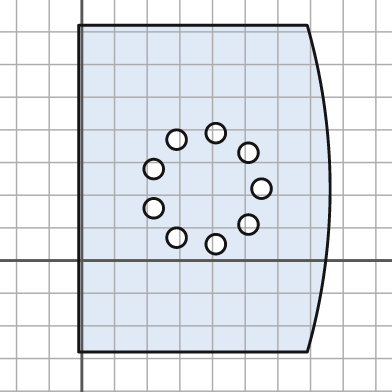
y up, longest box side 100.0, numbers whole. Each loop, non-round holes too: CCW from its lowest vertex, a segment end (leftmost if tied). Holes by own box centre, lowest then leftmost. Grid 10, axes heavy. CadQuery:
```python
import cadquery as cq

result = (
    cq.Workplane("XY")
    .moveTo(-1.0, -28.0)
    .lineTo(69.0, -28.0)
    .threePointArc((76.0, 22.0), (69.0, 72.0))
    .lineTo(-1.0, 72.0)
    .close()
    .moveTo(41.0, 5.0)
    .circle(3.0)
    .moveTo(29.0, 7.0)
    .circle(3.0)
    .moveTo(51.0, 11.0)
    .circle(3.0)
    .moveTo(22.0, 16.0)
    .circle(3.0)
    .moveTo(55.0, 22.0)
    .circle(3.0)
    .moveTo(22.0, 28.0)
    .circle(3.0)
    .moveTo(51.0, 33.0)
    .circle(3.0)
    .moveTo(29.0, 37.0)
    .circle(3.0)
    .moveTo(41.0, 39.0)
    .circle(3.0)
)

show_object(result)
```